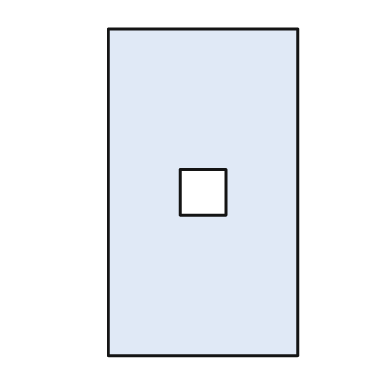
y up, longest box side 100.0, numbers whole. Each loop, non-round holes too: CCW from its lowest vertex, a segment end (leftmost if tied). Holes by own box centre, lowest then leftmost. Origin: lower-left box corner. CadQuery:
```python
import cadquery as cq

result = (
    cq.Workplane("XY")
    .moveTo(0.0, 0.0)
    .lineTo(58.0, 0.0)
    .lineTo(58.0, 100.0)
    .lineTo(0.0, 100.0)
    .close()
    .moveTo(22.0, 43.0)
    .lineTo(36.0, 43.0)
    .lineTo(36.0, 57.0)
    .lineTo(22.0, 57.0)
    .close()
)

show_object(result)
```